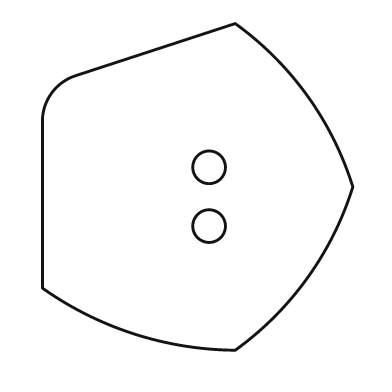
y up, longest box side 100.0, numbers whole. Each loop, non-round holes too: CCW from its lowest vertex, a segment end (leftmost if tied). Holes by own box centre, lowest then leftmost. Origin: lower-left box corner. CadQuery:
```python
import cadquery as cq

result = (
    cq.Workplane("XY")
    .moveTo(59.0, 0.0)
    .threePointArc((81.0, 22.0), (95.0, 50.0))
    .threePointArc((81.0, 78.0), (59.0, 100.0))
    .lineTo(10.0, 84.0)
    .threePointArc((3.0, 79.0), (0.0, 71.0))
    .lineTo(0.0, 19.0)
    .threePointArc((28.0, 5.0), (59.0, 0.0))
    .close()
    .moveTo(51.0, 38.0)
    .circle(5.0)
    .moveTo(51.0, 56.0)
    .circle(5.0)
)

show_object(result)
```